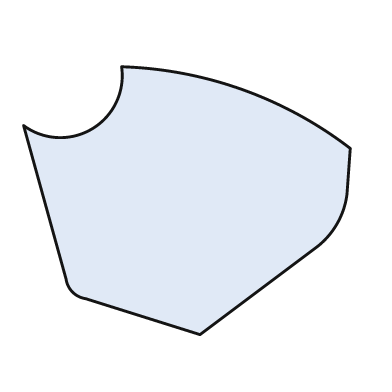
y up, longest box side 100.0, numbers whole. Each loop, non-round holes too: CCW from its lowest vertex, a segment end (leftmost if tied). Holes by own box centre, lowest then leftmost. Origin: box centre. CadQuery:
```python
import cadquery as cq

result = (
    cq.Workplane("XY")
    .moveTo(4.0, -41.0)
    .lineTo(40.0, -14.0)
    .threePointArc((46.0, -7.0), (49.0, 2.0))
    .lineTo(50.0, 16.0)
    .threePointArc((17.0, 34.0), (-20.0, 41.0))
    .threePointArc((-29.0, 22.0), (-50.0, 23.0))
    .lineTo(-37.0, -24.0)
    .threePointArc((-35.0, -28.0), (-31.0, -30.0))
    .close()
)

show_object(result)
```